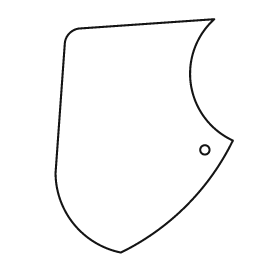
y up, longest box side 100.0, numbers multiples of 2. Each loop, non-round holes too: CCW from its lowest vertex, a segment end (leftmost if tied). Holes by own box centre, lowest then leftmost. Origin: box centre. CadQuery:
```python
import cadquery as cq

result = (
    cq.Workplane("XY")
    .moveTo(-10.0, -50.0)
    .threePointArc((18.0, -30.0), (38.0, -2.0))
    .threePointArc((20.0, 22.0), (30.0, 50.0))
    .lineTo(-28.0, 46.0)
    .threePointArc((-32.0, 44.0), (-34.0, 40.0))
    .lineTo(-38.0, -16.0)
    .threePointArc((-30.0, -38.0), (-10.0, -50.0))
    .close()
    .moveTo(26.0, -6.0)
    .circle(2.0)
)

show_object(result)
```